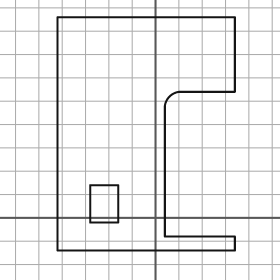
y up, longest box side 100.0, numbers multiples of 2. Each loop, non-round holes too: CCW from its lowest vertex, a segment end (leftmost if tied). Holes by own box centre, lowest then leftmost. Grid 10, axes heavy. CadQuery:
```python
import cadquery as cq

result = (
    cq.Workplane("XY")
    .moveTo(-42.0, -14.0)
    .lineTo(34.0, -14.0)
    .lineTo(34.0, -8.0)
    .lineTo(4.0, -8.0)
    .lineTo(4.0, 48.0)
    .threePointArc((6.0, 52.0), (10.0, 54.0))
    .lineTo(34.0, 54.0)
    .lineTo(34.0, 86.0)
    .lineTo(-42.0, 86.0)
    .close()
    .moveTo(-28.0, -2.0)
    .lineTo(-16.0, -2.0)
    .lineTo(-16.0, 14.0)
    .lineTo(-28.0, 14.0)
    .close()
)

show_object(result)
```